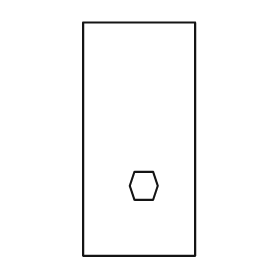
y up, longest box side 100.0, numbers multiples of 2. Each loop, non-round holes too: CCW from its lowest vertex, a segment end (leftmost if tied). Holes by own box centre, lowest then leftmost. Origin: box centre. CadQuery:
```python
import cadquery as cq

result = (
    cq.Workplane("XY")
    .moveTo(-24.0, -50.0)
    .lineTo(24.0, -50.0)
    .lineTo(24.0, 50.0)
    .lineTo(-24.0, 50.0)
    .close()
    .moveTo(-2.0, -26.0)
    .lineTo(6.0, -26.0)
    .lineTo(8.0, -20.0)
    .lineTo(6.0, -14.0)
    .lineTo(-2.0, -14.0)
    .lineTo(-4.0, -20.0)
    .close()
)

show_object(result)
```